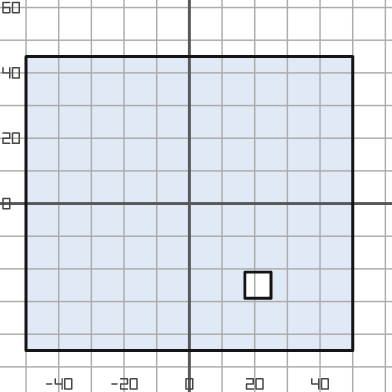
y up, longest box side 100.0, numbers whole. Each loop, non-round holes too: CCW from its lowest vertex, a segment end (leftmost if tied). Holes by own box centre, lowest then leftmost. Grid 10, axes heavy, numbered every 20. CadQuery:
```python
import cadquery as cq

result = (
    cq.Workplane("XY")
    .moveTo(-50.0, -45.0)
    .lineTo(50.0, -45.0)
    .lineTo(50.0, 45.0)
    .lineTo(-50.0, 45.0)
    .close()
    .moveTo(17.0, -29.0)
    .lineTo(25.0, -29.0)
    .lineTo(25.0, -21.0)
    .lineTo(17.0, -21.0)
    .close()
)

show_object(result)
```